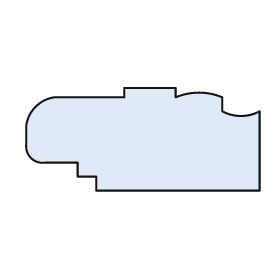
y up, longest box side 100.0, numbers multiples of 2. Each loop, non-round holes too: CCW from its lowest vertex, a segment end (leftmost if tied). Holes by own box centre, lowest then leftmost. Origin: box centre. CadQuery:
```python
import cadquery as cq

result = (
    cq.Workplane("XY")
    .moveTo(-20.0, -22.0)
    .lineTo(50.0, -22.0)
    .lineTo(50.0, 12.0)
    .threePointArc((42.0, 10.0), (34.0, 12.0))
    .lineTo(34.0, 18.0)
    .threePointArc((24.0, 20.0), (14.0, 18.0))
    .lineTo(14.0, 22.0)
    .lineTo(-8.0, 22.0)
    .lineTo(-8.0, 18.0)
    .lineTo(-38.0, 18.0)
    .threePointArc((-46.0, 14.0), (-50.0, 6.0))
    .lineTo(-50.0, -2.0)
    .threePointArc((-48.0, -8.0), (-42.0, -10.0))
    .lineTo(-28.0, -10.0)
    .lineTo(-28.0, -16.0)
    .lineTo(-20.0, -16.0)
    .close()
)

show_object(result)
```